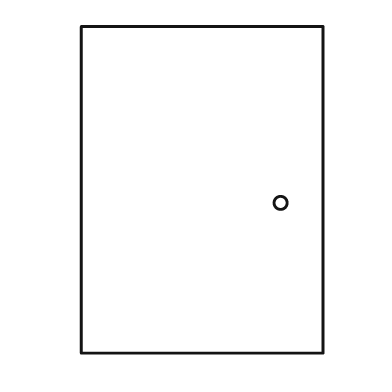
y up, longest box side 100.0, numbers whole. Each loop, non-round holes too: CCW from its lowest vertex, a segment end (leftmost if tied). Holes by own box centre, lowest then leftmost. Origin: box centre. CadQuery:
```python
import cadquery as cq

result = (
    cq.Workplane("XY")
    .moveTo(-37.0, -50.0)
    .lineTo(37.0, -50.0)
    .lineTo(37.0, 50.0)
    .lineTo(-37.0, 50.0)
    .close()
    .moveTo(24.0, -4.0)
    .circle(2.0)
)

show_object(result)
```